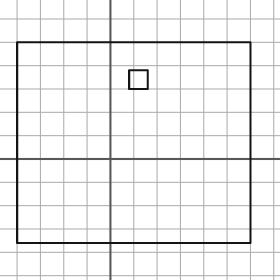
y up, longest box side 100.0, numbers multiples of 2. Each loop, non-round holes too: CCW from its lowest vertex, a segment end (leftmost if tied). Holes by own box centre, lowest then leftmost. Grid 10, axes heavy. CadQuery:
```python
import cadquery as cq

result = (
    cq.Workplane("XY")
    .moveTo(-40.0, -36.0)
    .lineTo(60.0, -36.0)
    .lineTo(60.0, 50.0)
    .lineTo(-40.0, 50.0)
    .close()
    .moveTo(8.0, 30.0)
    .lineTo(16.0, 30.0)
    .lineTo(16.0, 38.0)
    .lineTo(8.0, 38.0)
    .close()
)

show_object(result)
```